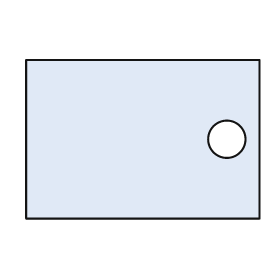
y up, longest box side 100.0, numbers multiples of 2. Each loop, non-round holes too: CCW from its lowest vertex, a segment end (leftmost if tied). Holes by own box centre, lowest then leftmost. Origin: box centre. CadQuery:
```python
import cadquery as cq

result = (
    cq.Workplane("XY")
    .moveTo(-50.0, -34.0)
    .lineTo(50.0, -34.0)
    .lineTo(50.0, 34.0)
    .lineTo(-50.0, 34.0)
    .close()
    .moveTo(36.0, 0.0)
    .circle(8.0)
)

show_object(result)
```